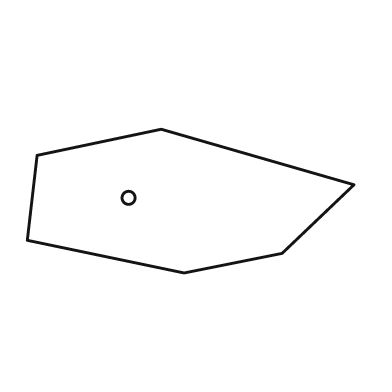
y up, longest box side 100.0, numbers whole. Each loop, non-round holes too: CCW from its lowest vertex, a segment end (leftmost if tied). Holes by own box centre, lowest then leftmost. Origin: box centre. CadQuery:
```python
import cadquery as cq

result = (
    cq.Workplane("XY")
    .moveTo(-2.0, -22.0)
    .lineTo(28.0, -16.0)
    .lineTo(50.0, 5.0)
    .lineTo(-9.0, 22.0)
    .lineTo(-47.0, 14.0)
    .lineTo(-50.0, -12.0)
    .close()
    .moveTo(-19.0, 1.0)
    .circle(2.0)
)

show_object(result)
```